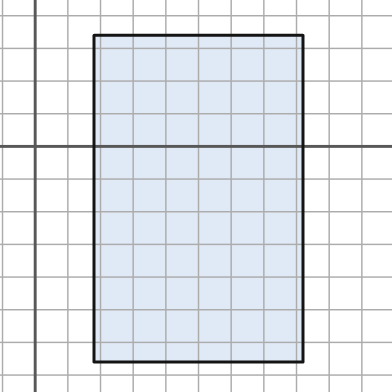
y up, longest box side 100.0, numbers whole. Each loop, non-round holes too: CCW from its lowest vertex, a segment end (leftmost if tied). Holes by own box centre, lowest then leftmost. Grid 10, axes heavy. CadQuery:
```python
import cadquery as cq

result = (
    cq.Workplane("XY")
    .moveTo(18.0, -66.0)
    .lineTo(82.0, -66.0)
    .lineTo(82.0, 34.0)
    .lineTo(18.0, 34.0)
    .close()
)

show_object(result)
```